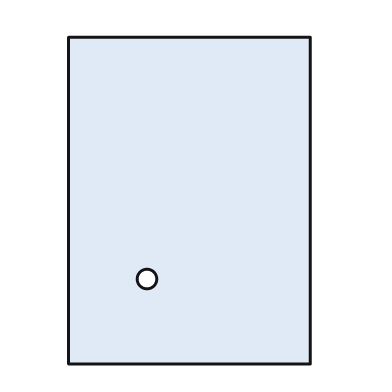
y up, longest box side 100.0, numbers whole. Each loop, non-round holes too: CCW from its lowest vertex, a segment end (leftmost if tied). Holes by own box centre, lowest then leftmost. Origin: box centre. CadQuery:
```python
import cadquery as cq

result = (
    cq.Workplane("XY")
    .moveTo(-37.0, -50.0)
    .lineTo(37.0, -50.0)
    .lineTo(37.0, 50.0)
    .lineTo(-37.0, 50.0)
    .close()
    .moveTo(-13.0, -24.0)
    .circle(3.0)
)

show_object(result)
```